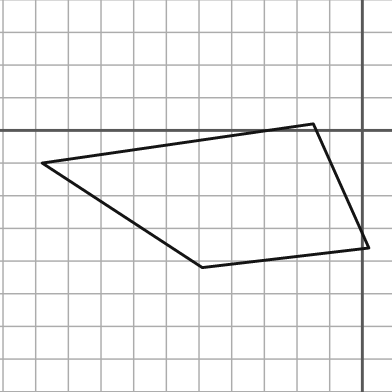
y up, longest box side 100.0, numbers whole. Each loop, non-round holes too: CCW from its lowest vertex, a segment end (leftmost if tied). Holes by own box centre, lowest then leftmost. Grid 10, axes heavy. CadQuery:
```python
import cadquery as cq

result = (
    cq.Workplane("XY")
    .moveTo(-49.0, -42.0)
    .lineTo(2.0, -36.0)
    .lineTo(-15.0, 2.0)
    .lineTo(-98.0, -10.0)
    .close()
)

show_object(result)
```